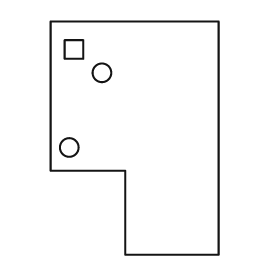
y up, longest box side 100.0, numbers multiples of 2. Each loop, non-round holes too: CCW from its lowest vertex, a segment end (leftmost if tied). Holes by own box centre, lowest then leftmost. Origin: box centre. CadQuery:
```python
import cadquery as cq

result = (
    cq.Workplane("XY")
    .moveTo(-4.0, -50.0)
    .lineTo(36.0, -50.0)
    .lineTo(36.0, 50.0)
    .lineTo(-36.0, 50.0)
    .lineTo(-36.0, -14.0)
    .lineTo(-4.0, -14.0)
    .close()
    .moveTo(-28.0, -4.0)
    .circle(4.0)
    .moveTo(-14.0, 28.0)
    .circle(4.0)
    .moveTo(-30.0, 34.0)
    .lineTo(-22.0, 34.0)
    .lineTo(-22.0, 42.0)
    .lineTo(-30.0, 42.0)
    .close()
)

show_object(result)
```